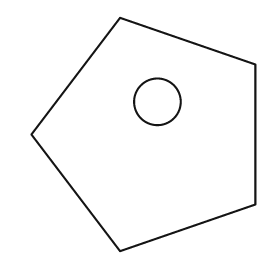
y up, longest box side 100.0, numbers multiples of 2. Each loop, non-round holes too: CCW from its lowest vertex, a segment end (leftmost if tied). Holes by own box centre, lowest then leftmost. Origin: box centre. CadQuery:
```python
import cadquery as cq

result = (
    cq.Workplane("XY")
    .moveTo(-10.0, -50.0)
    .lineTo(48.0, -30.0)
    .lineTo(48.0, 30.0)
    .lineTo(-10.0, 50.0)
    .lineTo(-48.0, 0.0)
    .close()
    .moveTo(6.0, 14.0)
    .circle(10.0)
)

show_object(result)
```